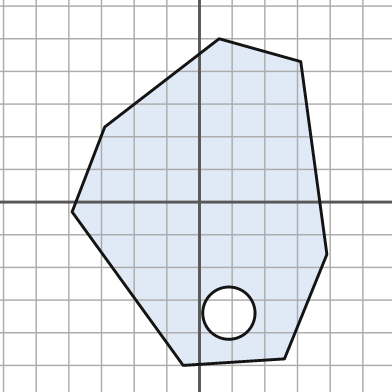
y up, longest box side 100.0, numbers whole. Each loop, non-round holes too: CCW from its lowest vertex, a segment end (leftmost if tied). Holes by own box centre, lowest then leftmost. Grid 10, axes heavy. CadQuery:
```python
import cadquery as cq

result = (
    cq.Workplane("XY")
    .moveTo(-5.0, -50.0)
    .lineTo(26.0, -48.0)
    .lineTo(39.0, -16.0)
    .lineTo(31.0, 43.0)
    .lineTo(6.0, 50.0)
    .lineTo(-29.0, 23.0)
    .lineTo(-39.0, -3.0)
    .close()
    .moveTo(9.0, -34.0)
    .circle(8.0)
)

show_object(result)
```